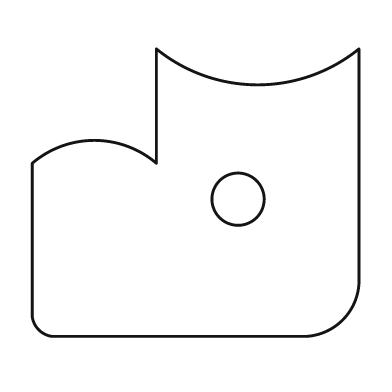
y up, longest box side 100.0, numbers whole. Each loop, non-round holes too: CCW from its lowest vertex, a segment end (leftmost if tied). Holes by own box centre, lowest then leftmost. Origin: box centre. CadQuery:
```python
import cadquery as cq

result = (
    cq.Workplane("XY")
    .moveTo(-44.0, -44.0)
    .lineTo(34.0, -44.0)
    .threePointArc((45.0, -39.0), (50.0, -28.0))
    .lineTo(50.0, 44.0)
    .threePointArc((19.0, 33.0), (-12.0, 44.0))
    .lineTo(-12.0, 9.0)
    .threePointArc((-31.0, 16.0), (-50.0, 9.0))
    .lineTo(-50.0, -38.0)
    .threePointArc((-48.0, -42.0), (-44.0, -44.0))
    .close()
    .moveTo(13.0, -2.0)
    .circle(8.0)
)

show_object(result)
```